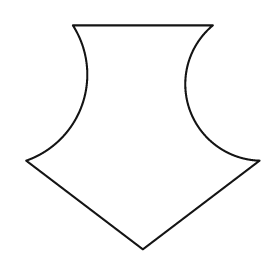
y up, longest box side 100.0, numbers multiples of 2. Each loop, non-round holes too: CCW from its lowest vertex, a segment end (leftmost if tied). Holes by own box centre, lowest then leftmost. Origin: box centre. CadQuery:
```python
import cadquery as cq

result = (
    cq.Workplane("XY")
    .moveTo(0.0, -48.0)
    .lineTo(50.0, -10.0)
    .threePointArc((20.0, 12.0), (30.0, 48.0))
    .lineTo(-30.0, 48.0)
    .threePointArc((-26.0, 14.0), (-50.0, -10.0))
    .close()
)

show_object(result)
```